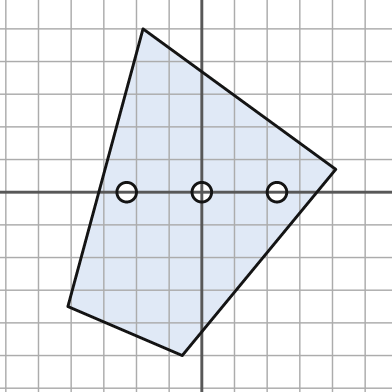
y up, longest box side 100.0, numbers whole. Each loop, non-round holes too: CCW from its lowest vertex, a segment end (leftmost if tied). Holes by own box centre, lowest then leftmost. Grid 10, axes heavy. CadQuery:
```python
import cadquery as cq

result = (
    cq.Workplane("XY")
    .moveTo(-6.0, -50.0)
    .lineTo(41.0, 7.0)
    .lineTo(-18.0, 50.0)
    .lineTo(-41.0, -35.0)
    .close()
    .moveTo(-23.0, 0.0)
    .circle(3.0)
    .moveTo(0.0, 0.0)
    .circle(3.0)
    .moveTo(23.0, 0.0)
    .circle(3.0)
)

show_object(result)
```